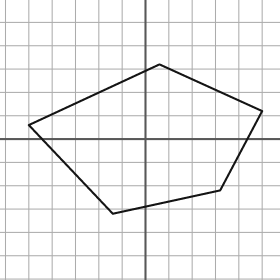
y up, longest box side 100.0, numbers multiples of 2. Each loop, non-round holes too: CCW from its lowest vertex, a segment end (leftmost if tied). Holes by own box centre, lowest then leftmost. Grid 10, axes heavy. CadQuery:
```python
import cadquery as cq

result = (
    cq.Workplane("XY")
    .moveTo(-14.0, -32.0)
    .lineTo(32.0, -22.0)
    .lineTo(50.0, 12.0)
    .lineTo(6.0, 32.0)
    .lineTo(-50.0, 6.0)
    .close()
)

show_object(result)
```